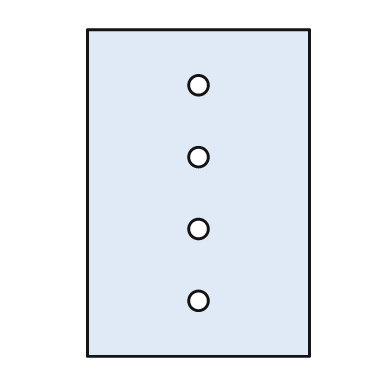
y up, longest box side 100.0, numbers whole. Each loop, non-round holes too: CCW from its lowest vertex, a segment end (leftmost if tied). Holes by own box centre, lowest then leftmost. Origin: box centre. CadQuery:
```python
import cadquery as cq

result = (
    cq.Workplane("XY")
    .moveTo(-34.0, -50.0)
    .lineTo(34.0, -50.0)
    .lineTo(34.0, 50.0)
    .lineTo(-34.0, 50.0)
    .close()
    .moveTo(0.0, -33.0)
    .circle(3.0)
    .moveTo(0.0, -11.0)
    .circle(3.0)
    .moveTo(0.0, 11.0)
    .circle(3.0)
    .moveTo(0.0, 33.0)
    .circle(3.0)
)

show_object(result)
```